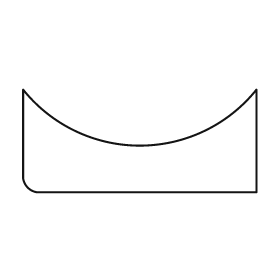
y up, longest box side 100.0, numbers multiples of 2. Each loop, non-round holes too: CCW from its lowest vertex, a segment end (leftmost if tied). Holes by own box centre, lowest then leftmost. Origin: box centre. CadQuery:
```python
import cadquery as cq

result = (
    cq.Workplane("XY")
    .moveTo(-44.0, -22.0)
    .lineTo(50.0, -22.0)
    .lineTo(50.0, 22.0)
    .threePointArc((0.0, -2.0), (-50.0, 22.0))
    .lineTo(-50.0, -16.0)
    .threePointArc((-48.0, -20.0), (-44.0, -22.0))
    .close()
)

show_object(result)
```